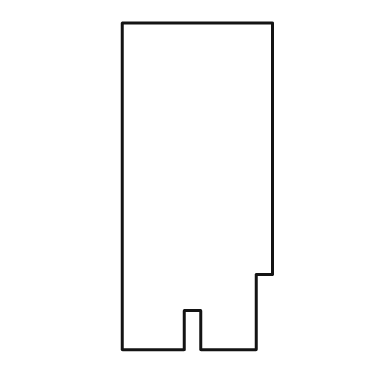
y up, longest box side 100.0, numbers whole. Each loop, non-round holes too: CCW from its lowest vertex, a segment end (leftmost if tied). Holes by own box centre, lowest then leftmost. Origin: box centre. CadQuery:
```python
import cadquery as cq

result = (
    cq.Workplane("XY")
    .moveTo(-23.0, -50.0)
    .lineTo(-4.0, -50.0)
    .lineTo(-4.0, -38.0)
    .lineTo(1.0, -38.0)
    .lineTo(1.0, -50.0)
    .lineTo(18.0, -50.0)
    .lineTo(18.0, -27.0)
    .lineTo(23.0, -27.0)
    .lineTo(23.0, 50.0)
    .lineTo(-23.0, 50.0)
    .close()
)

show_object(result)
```